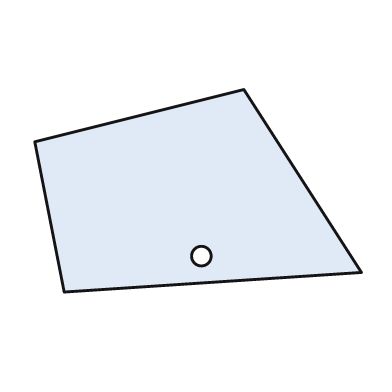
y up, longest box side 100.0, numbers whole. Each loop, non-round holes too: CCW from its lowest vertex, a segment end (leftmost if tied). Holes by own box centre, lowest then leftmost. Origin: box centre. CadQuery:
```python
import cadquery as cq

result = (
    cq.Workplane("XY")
    .moveTo(-41.0, -31.0)
    .lineTo(50.0, -25.0)
    .lineTo(14.0, 31.0)
    .lineTo(-50.0, 15.0)
    .close()
    .moveTo(1.0, -20.0)
    .circle(3.0)
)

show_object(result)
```